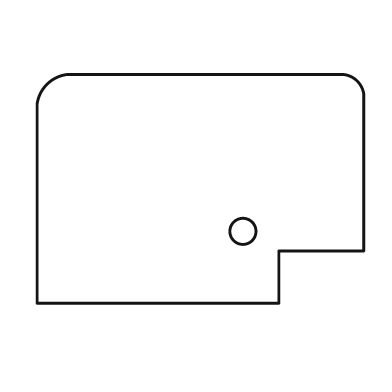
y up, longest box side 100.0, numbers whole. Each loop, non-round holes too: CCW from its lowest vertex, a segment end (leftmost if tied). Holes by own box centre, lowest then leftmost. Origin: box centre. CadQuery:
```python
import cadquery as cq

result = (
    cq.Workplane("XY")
    .moveTo(-50.0, -35.0)
    .lineTo(24.0, -35.0)
    .lineTo(24.0, -19.0)
    .lineTo(50.0, -19.0)
    .lineTo(50.0, 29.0)
    .threePointArc((48.0, 33.0), (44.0, 35.0))
    .lineTo(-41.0, 35.0)
    .threePointArc((-47.0, 32.0), (-50.0, 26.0))
    .close()
    .moveTo(13.0, -13.0)
    .circle(4.0)
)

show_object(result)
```